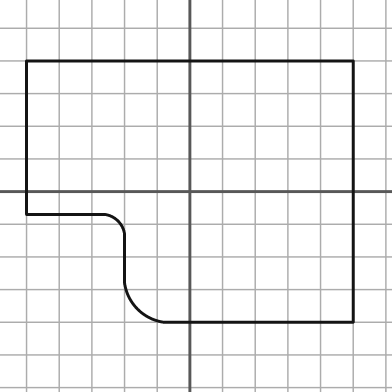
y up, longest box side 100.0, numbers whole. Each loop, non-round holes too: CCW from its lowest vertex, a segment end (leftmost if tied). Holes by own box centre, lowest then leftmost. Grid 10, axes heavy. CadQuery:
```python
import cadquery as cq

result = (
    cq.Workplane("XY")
    .moveTo(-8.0, -40.0)
    .lineTo(50.0, -40.0)
    .lineTo(50.0, 40.0)
    .lineTo(-50.0, 40.0)
    .lineTo(-50.0, -7.0)
    .lineTo(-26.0, -7.0)
    .threePointArc((-22.0, -9.0), (-20.0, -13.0))
    .lineTo(-20.0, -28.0)
    .threePointArc((-16.0, -36.0), (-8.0, -40.0))
    .close()
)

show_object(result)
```